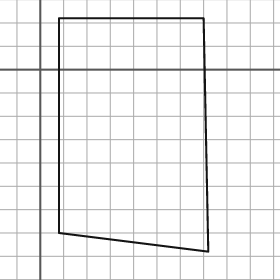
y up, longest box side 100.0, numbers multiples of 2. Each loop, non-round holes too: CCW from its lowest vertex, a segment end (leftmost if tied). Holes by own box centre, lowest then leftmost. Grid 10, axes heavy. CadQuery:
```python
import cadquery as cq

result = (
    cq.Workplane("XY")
    .moveTo(72.0, -78.0)
    .lineTo(70.0, 22.0)
    .lineTo(8.0, 22.0)
    .lineTo(8.0, -70.0)
    .close()
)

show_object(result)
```